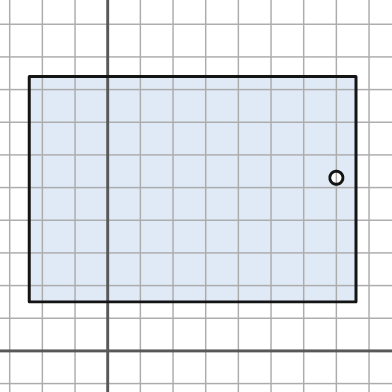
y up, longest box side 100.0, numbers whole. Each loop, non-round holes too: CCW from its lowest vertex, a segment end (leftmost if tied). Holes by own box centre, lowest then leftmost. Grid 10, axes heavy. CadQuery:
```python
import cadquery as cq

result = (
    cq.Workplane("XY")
    .moveTo(-24.0, 15.0)
    .lineTo(76.0, 15.0)
    .lineTo(76.0, 84.0)
    .lineTo(-24.0, 84.0)
    .close()
    .moveTo(70.0, 53.0)
    .circle(2.0)
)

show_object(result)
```